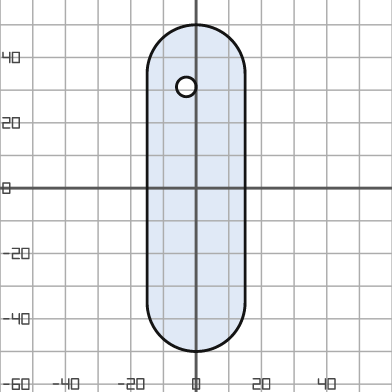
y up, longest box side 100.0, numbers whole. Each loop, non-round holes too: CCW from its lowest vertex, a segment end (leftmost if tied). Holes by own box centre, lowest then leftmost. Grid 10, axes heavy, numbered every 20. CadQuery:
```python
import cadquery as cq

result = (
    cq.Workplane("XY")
    .moveTo(-15.0, -35.0)
    .threePointArc((0.0, -50.0), (15.0, -35.0))
    .lineTo(15.0, 35.0)
    .threePointArc((0.0, 50.0), (-15.0, 35.0))
    .close()
    .moveTo(-3.0, 31.0)
    .circle(3.0)
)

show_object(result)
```